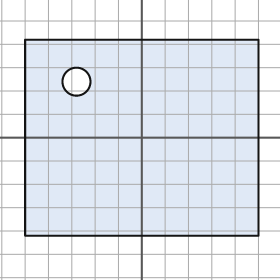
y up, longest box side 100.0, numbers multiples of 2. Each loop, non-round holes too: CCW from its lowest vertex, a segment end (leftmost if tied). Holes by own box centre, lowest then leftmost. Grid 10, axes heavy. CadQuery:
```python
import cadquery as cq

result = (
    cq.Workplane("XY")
    .moveTo(-50.0, -42.0)
    .lineTo(50.0, -42.0)
    .lineTo(50.0, 42.0)
    .lineTo(-50.0, 42.0)
    .close()
    .moveTo(-28.0, 24.0)
    .circle(6.0)
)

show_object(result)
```